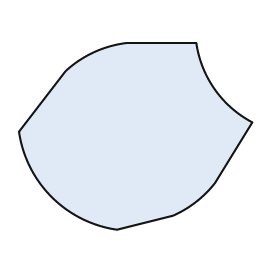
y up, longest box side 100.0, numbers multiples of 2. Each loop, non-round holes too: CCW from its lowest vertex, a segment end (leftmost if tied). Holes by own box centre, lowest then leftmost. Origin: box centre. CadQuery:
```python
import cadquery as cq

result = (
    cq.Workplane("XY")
    .moveTo(-8.0, -40.0)
    .lineTo(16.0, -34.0)
    .threePointArc((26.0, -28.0), (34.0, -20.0))
    .lineTo(50.0, 6.0)
    .threePointArc((34.0, 20.0), (26.0, 40.0))
    .lineTo(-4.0, 40.0)
    .threePointArc((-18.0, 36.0), (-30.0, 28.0))
    .lineTo(-50.0, 2.0)
    .threePointArc((-36.0, -26.0), (-8.0, -40.0))
    .close()
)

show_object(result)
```